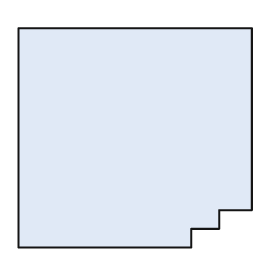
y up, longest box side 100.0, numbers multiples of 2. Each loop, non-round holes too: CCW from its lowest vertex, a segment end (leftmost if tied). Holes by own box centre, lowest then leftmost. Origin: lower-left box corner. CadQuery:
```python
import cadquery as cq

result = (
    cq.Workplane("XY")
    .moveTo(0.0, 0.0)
    .lineTo(74.0, 0.0)
    .lineTo(74.0, 8.0)
    .lineTo(86.0, 8.0)
    .lineTo(86.0, 16.0)
    .lineTo(100.0, 16.0)
    .lineTo(100.0, 94.0)
    .lineTo(0.0, 94.0)
    .close()
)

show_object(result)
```